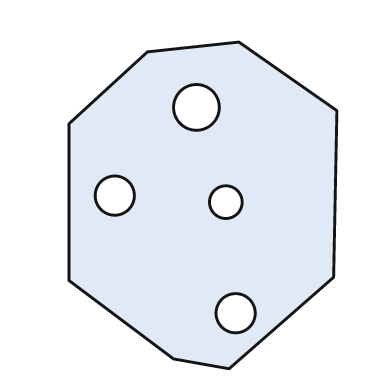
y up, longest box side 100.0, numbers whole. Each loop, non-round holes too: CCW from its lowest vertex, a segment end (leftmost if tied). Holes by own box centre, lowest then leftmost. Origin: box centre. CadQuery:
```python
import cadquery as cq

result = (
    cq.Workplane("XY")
    .moveTo(8.0, -50.0)
    .lineTo(40.0, -22.0)
    .lineTo(41.0, 29.0)
    .lineTo(11.0, 50.0)
    .lineTo(-17.0, 47.0)
    .lineTo(-41.0, 25.0)
    .lineTo(-41.0, -23.0)
    .lineTo(-9.0, -47.0)
    .close()
    .moveTo(10.0, -33.0)
    .circle(6.0)
    .moveTo(7.0, 1.0)
    .circle(5.0)
    .moveTo(-27.0, 3.0)
    .circle(6.0)
    .moveTo(-2.0, 30.0)
    .circle(7.0)
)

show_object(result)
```